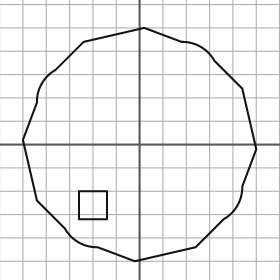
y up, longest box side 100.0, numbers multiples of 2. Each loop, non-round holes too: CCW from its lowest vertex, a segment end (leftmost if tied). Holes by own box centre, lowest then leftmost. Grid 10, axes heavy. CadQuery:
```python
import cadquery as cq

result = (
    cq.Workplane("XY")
    .moveTo(-2.0, -50.0)
    .lineTo(24.0, -44.0)
    .lineTo(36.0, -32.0)
    .threePointArc((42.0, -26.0), (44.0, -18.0))
    .lineTo(50.0, -2.0)
    .lineTo(44.0, 24.0)
    .lineTo(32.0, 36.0)
    .threePointArc((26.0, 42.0), (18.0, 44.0))
    .lineTo(2.0, 50.0)
    .lineTo(-24.0, 44.0)
    .lineTo(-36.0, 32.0)
    .threePointArc((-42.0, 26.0), (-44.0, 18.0))
    .lineTo(-50.0, 2.0)
    .lineTo(-44.0, -24.0)
    .lineTo(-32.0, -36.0)
    .threePointArc((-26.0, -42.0), (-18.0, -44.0))
    .close()
    .moveTo(-26.0, -32.0)
    .lineTo(-14.0, -32.0)
    .lineTo(-14.0, -20.0)
    .lineTo(-26.0, -20.0)
    .close()
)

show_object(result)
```